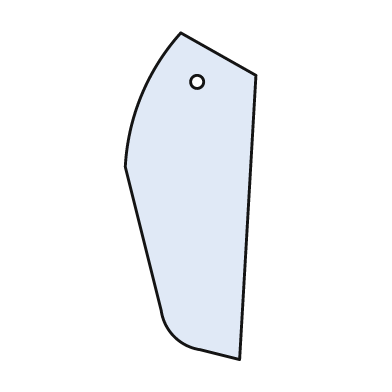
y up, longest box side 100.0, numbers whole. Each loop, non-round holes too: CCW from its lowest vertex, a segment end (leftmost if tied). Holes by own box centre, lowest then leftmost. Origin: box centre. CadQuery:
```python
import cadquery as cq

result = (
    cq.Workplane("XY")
    .moveTo(15.0, -50.0)
    .lineTo(20.0, 37.0)
    .lineTo(-3.0, 50.0)
    .threePointArc((-15.0, 31.0), (-20.0, 9.0))
    .lineTo(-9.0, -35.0)
    .threePointArc((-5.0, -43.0), (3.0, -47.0))
    .close()
    .moveTo(2.0, 35.0)
    .circle(2.0)
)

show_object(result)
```